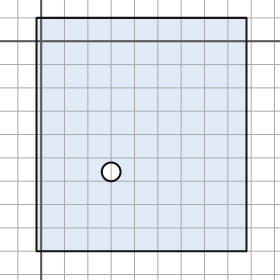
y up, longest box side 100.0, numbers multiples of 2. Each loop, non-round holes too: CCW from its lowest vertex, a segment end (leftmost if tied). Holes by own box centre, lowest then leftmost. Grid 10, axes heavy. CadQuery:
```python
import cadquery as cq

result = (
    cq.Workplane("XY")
    .moveTo(-2.0, -90.0)
    .lineTo(88.0, -90.0)
    .lineTo(88.0, 10.0)
    .lineTo(-2.0, 10.0)
    .close()
    .moveTo(30.0, -56.0)
    .circle(4.0)
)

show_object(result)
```